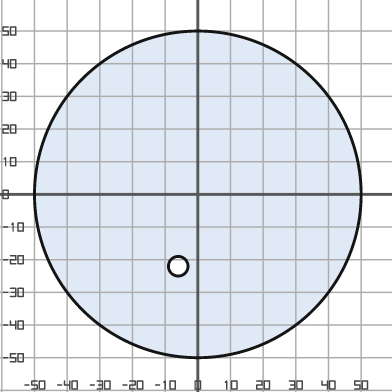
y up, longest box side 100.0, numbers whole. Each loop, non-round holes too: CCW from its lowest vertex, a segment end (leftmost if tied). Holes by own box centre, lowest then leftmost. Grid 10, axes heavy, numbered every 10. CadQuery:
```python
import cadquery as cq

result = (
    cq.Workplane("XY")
    .moveTo(0.0, 0.0)
    .circle(50.0)
    .moveTo(-6.0, -22.0)
    .circle(3.0)
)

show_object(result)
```